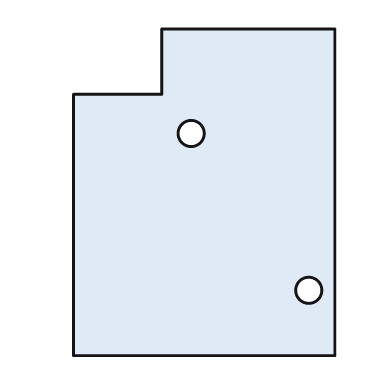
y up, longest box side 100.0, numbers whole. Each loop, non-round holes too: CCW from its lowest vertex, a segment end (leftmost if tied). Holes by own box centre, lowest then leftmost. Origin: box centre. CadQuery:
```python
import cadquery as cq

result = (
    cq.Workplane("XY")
    .moveTo(-40.0, -50.0)
    .lineTo(40.0, -50.0)
    .lineTo(40.0, 50.0)
    .lineTo(-13.0, 50.0)
    .lineTo(-13.0, 30.0)
    .lineTo(-40.0, 30.0)
    .close()
    .moveTo(32.0, -30.0)
    .circle(4.0)
    .moveTo(-4.0, 18.0)
    .circle(4.0)
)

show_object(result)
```